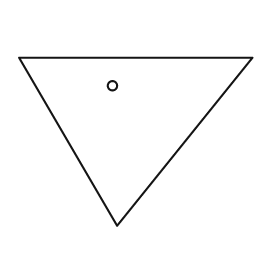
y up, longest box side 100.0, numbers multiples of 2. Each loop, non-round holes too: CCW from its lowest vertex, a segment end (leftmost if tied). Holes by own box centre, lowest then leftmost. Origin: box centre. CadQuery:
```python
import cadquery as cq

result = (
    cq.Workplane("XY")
    .moveTo(-8.0, -36.0)
    .lineTo(50.0, 36.0)
    .lineTo(-50.0, 36.0)
    .close()
    .moveTo(-10.0, 24.0)
    .circle(2.0)
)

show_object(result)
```